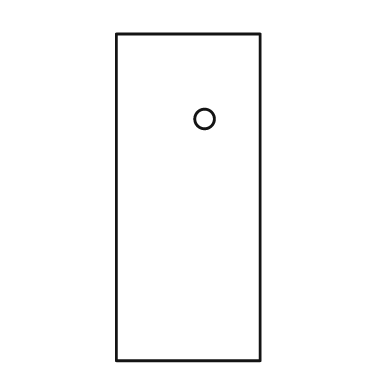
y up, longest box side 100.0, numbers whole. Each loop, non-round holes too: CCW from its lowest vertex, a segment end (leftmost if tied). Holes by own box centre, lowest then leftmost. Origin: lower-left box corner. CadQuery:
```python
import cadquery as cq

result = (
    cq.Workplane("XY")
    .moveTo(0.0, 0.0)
    .lineTo(44.0, 0.0)
    .lineTo(44.0, 100.0)
    .lineTo(0.0, 100.0)
    .close()
    .moveTo(27.0, 74.0)
    .circle(3.0)
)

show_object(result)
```